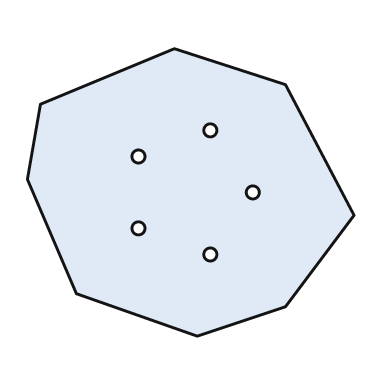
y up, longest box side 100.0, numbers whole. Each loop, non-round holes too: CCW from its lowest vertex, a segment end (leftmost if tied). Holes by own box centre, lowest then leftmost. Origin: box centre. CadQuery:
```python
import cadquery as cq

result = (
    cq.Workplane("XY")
    .moveTo(2.0, -44.0)
    .lineTo(29.0, -35.0)
    .lineTo(50.0, -7.0)
    .lineTo(29.0, 33.0)
    .lineTo(-5.0, 44.0)
    .lineTo(-46.0, 27.0)
    .lineTo(-50.0, 4.0)
    .lineTo(-35.0, -31.0)
    .close()
    .moveTo(6.0, -19.0)
    .circle(2.0)
    .moveTo(-16.0, -11.0)
    .circle(2.0)
    .moveTo(19.0, 0.0)
    .circle(2.0)
    .moveTo(-16.0, 11.0)
    .circle(2.0)
    .moveTo(6.0, 19.0)
    .circle(2.0)
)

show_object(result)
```